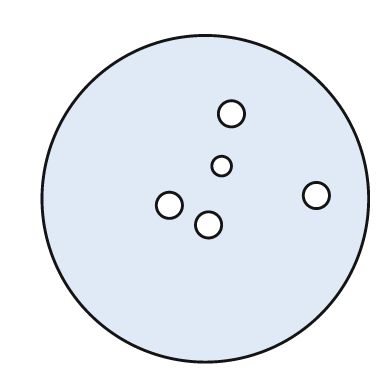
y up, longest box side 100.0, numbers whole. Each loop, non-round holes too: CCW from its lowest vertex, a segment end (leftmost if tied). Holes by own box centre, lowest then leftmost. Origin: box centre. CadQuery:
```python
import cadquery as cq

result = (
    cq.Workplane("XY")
    .moveTo(0.0, 0.0)
    .circle(50.0)
    .moveTo(1.0, -8.0)
    .circle(4.0)
    .moveTo(-11.0, -2.0)
    .circle(4.0)
    .moveTo(34.0, 1.0)
    .circle(4.0)
    .moveTo(5.0, 10.0)
    .circle(3.0)
    .moveTo(8.0, 26.0)
    .circle(4.0)
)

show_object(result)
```